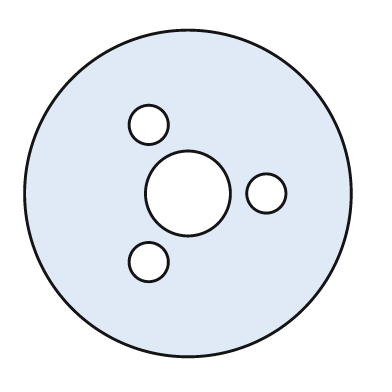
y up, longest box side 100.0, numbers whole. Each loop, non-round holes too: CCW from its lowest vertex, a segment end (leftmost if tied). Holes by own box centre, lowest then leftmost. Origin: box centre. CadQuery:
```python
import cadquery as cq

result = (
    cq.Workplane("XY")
    .moveTo(0.0, 0.0)
    .circle(50.0)
    .moveTo(-12.0, -21.0)
    .circle(6.0)
    .moveTo(0.0, 0.0)
    .circle(13.0)
    .moveTo(24.0, 0.0)
    .circle(6.0)
    .moveTo(-12.0, 21.0)
    .circle(6.0)
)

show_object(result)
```